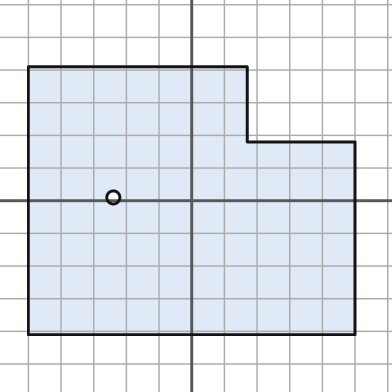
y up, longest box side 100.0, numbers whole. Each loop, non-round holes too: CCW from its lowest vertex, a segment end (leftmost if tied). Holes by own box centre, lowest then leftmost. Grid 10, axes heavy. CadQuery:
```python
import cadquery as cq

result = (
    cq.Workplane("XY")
    .moveTo(-50.0, -41.0)
    .lineTo(50.0, -41.0)
    .lineTo(50.0, 18.0)
    .lineTo(17.0, 18.0)
    .lineTo(17.0, 41.0)
    .lineTo(-50.0, 41.0)
    .close()
    .moveTo(-24.0, 1.0)
    .circle(2.0)
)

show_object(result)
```